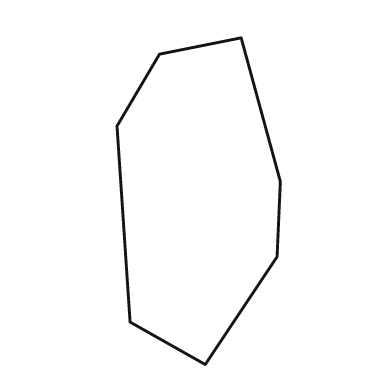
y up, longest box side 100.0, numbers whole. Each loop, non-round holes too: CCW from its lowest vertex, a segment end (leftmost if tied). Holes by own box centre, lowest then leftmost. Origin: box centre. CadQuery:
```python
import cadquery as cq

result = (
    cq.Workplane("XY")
    .moveTo(2.0, -50.0)
    .lineTo(24.0, -17.0)
    .lineTo(25.0, 6.0)
    .lineTo(13.0, 50.0)
    .lineTo(-12.0, 45.0)
    .lineTo(-25.0, 23.0)
    .lineTo(-21.0, -37.0)
    .close()
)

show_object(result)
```